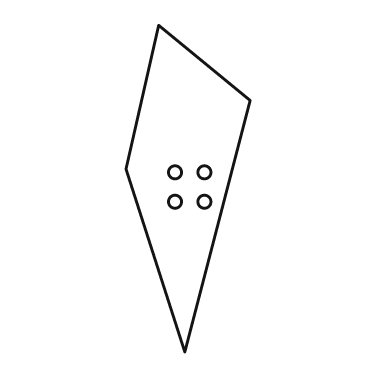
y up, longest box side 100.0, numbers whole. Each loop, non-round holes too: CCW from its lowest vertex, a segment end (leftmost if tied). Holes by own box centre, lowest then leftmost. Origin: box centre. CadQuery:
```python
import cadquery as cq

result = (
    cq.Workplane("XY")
    .moveTo(-1.0, -50.0)
    .lineTo(19.0, 27.0)
    .lineTo(-9.0, 50.0)
    .lineTo(-19.0, 6.0)
    .close()
    .moveTo(-4.0, -4.0)
    .circle(2.0)
    .moveTo(5.0, -4.0)
    .circle(2.0)
    .moveTo(-4.0, 5.0)
    .circle(2.0)
    .moveTo(5.0, 5.0)
    .circle(2.0)
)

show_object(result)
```